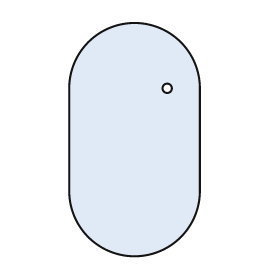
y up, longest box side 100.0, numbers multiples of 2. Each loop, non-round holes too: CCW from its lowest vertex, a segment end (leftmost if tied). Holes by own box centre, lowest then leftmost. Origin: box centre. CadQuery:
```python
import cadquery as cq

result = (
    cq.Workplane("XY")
    .moveTo(-28.0, -22.0)
    .threePointArc((0.0, -50.0), (28.0, -22.0))
    .lineTo(28.0, 22.0)
    .threePointArc((0.0, 50.0), (-28.0, 22.0))
    .close()
    .moveTo(14.0, 22.0)
    .circle(2.0)
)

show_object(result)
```